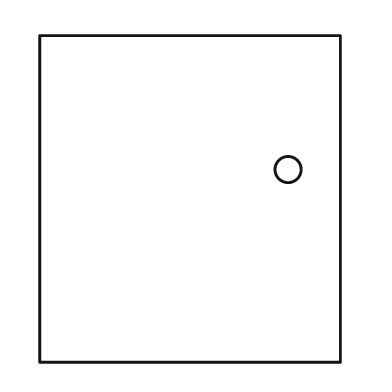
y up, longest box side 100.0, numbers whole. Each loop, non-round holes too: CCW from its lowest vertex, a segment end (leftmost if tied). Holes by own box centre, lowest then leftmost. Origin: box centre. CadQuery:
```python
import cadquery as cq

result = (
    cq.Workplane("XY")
    .moveTo(-46.0, -50.0)
    .lineTo(46.0, -50.0)
    .lineTo(46.0, 50.0)
    .lineTo(-46.0, 50.0)
    .close()
    .moveTo(30.0, 9.0)
    .circle(4.0)
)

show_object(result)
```